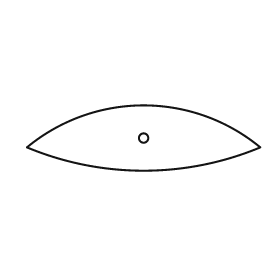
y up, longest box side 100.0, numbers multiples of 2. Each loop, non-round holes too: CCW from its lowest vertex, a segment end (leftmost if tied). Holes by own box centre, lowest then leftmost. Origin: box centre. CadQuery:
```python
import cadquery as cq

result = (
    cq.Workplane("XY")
    .moveTo(-50.0, -4.0)
    .threePointArc((0.0, -14.0), (50.0, -4.0))
    .threePointArc((0.0, 14.0), (-50.0, -4.0))
    .close()
    .moveTo(0.0, 0.0)
    .circle(2.0)
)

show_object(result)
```